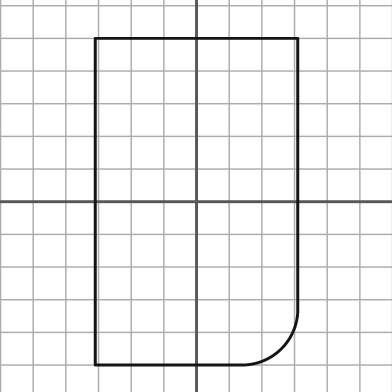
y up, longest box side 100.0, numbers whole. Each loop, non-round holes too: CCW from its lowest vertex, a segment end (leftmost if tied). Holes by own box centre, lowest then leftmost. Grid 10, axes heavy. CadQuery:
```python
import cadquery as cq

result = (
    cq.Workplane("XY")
    .moveTo(-31.0, -50.0)
    .lineTo(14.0, -50.0)
    .threePointArc((26.0, -45.0), (31.0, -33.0))
    .lineTo(31.0, 50.0)
    .lineTo(-31.0, 50.0)
    .close()
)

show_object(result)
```